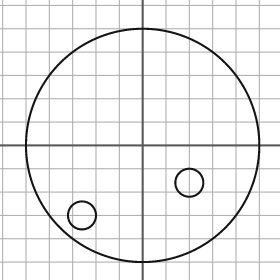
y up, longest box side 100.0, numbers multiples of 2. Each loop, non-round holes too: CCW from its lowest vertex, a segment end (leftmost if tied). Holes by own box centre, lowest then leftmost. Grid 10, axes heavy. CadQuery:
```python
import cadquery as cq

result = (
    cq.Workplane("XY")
    .moveTo(0.0, 0.0)
    .circle(50.0)
    .moveTo(-26.0, -30.0)
    .circle(6.0)
    .moveTo(20.0, -16.0)
    .circle(6.0)
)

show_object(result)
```